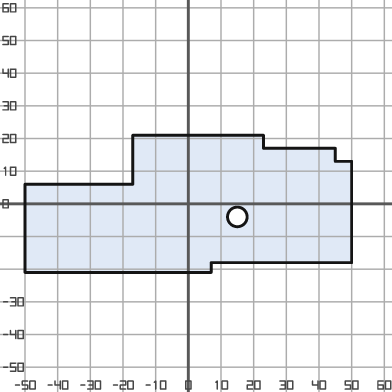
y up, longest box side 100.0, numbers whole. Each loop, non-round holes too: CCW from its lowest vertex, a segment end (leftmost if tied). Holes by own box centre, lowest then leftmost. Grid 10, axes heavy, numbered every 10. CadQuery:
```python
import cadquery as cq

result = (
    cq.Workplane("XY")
    .moveTo(-50.0, -21.0)
    .lineTo(7.0, -21.0)
    .lineTo(7.0, -18.0)
    .lineTo(50.0, -18.0)
    .lineTo(50.0, 13.0)
    .lineTo(45.0, 13.0)
    .lineTo(45.0, 17.0)
    .lineTo(23.0, 17.0)
    .lineTo(23.0, 21.0)
    .lineTo(-17.0, 21.0)
    .lineTo(-17.0, 6.0)
    .lineTo(-50.0, 6.0)
    .close()
    .moveTo(15.0, -4.0)
    .circle(3.0)
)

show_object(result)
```